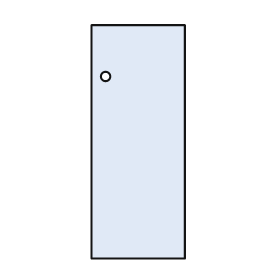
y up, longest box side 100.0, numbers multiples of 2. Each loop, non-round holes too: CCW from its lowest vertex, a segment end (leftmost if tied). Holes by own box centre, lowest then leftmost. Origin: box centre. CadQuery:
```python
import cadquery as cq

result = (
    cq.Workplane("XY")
    .moveTo(-20.0, -50.0)
    .lineTo(20.0, -50.0)
    .lineTo(20.0, 50.0)
    .lineTo(-20.0, 50.0)
    .close()
    .moveTo(-14.0, 28.0)
    .circle(2.0)
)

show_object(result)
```